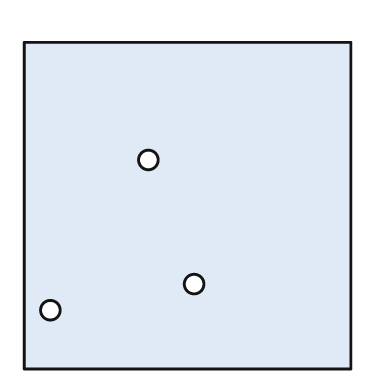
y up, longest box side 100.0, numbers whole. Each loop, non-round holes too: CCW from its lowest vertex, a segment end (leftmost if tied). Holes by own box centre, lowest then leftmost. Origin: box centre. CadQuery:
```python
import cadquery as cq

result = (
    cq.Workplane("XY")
    .moveTo(-50.0, -50.0)
    .lineTo(50.0, -50.0)
    .lineTo(50.0, 50.0)
    .lineTo(-50.0, 50.0)
    .close()
    .moveTo(-42.0, -32.0)
    .circle(3.0)
    .moveTo(2.0, -24.0)
    .circle(3.0)
    .moveTo(-12.0, 14.0)
    .circle(3.0)
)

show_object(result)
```